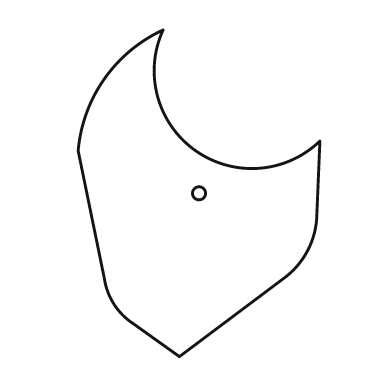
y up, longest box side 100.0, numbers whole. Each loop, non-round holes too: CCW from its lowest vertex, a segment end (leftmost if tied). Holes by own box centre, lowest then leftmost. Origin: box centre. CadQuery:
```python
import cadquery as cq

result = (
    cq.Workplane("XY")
    .moveTo(-6.0, -50.0)
    .lineTo(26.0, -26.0)
    .threePointArc((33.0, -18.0), (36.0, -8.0))
    .lineTo(37.0, 16.0)
    .threePointArc((-1.0, 13.0), (-11.0, 50.0))
    .threePointArc((-29.0, 35.0), (-37.0, 13.0))
    .lineTo(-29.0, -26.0)
    .threePointArc((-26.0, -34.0), (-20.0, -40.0))
    .close()
    .moveTo(0.0, 0.0)
    .circle(2.0)
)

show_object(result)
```